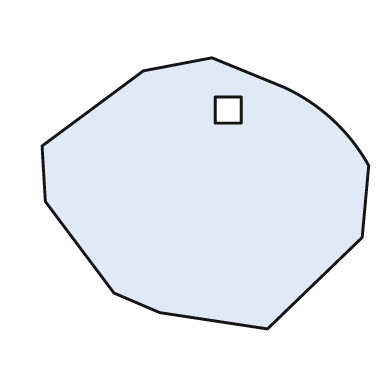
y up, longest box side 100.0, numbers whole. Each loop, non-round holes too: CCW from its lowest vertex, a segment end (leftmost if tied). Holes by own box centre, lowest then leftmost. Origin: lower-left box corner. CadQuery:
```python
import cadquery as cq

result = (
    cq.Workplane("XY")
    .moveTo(69.0, 0.0)
    .lineTo(98.0, 28.0)
    .lineTo(100.0, 50.0)
    .threePointArc((89.0, 64.0), (74.0, 74.0))
    .lineTo(52.0, 83.0)
    .lineTo(31.0, 79.0)
    .lineTo(0.0, 56.0)
    .lineTo(1.0, 39.0)
    .lineTo(22.0, 11.0)
    .lineTo(36.0, 5.0)
    .close()
    .moveTo(53.0, 63.0)
    .lineTo(61.0, 63.0)
    .lineTo(61.0, 71.0)
    .lineTo(53.0, 71.0)
    .close()
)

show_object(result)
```